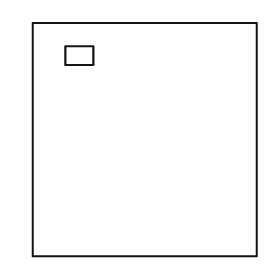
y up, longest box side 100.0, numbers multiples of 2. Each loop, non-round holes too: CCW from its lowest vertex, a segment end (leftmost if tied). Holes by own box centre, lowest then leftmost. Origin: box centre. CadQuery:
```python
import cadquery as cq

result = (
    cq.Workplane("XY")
    .moveTo(-48.0, -50.0)
    .lineTo(48.0, -50.0)
    .lineTo(48.0, 50.0)
    .lineTo(-48.0, 50.0)
    .close()
    .moveTo(-34.0, 32.0)
    .lineTo(-22.0, 32.0)
    .lineTo(-22.0, 40.0)
    .lineTo(-34.0, 40.0)
    .close()
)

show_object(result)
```